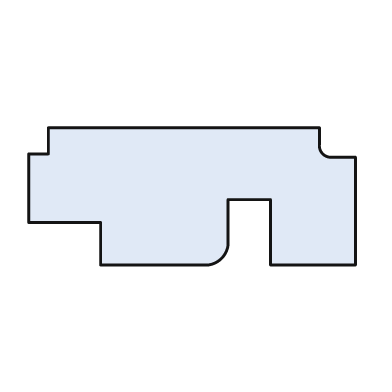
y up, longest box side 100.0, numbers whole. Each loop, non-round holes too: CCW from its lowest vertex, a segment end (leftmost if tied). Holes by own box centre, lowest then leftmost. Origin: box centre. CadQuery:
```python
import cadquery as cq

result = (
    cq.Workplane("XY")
    .moveTo(-28.0, -21.0)
    .lineTo(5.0, -21.0)
    .threePointArc((9.0, -19.0), (11.0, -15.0))
    .lineTo(11.0, -1.0)
    .lineTo(24.0, -1.0)
    .lineTo(24.0, -21.0)
    .lineTo(50.0, -21.0)
    .lineTo(50.0, 12.0)
    .lineTo(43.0, 12.0)
    .threePointArc((40.0, 13.0), (39.0, 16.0))
    .lineTo(39.0, 21.0)
    .lineTo(-44.0, 21.0)
    .lineTo(-44.0, 13.0)
    .lineTo(-50.0, 13.0)
    .lineTo(-50.0, -8.0)
    .lineTo(-28.0, -8.0)
    .close()
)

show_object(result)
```